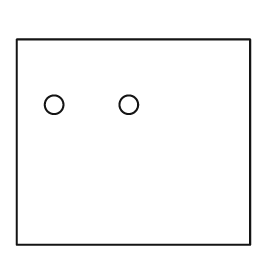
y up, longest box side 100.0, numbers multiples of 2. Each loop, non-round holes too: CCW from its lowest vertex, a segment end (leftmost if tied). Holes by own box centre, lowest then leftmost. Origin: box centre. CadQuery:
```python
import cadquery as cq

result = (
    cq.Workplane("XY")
    .moveTo(-50.0, -44.0)
    .lineTo(50.0, -44.0)
    .lineTo(50.0, 44.0)
    .lineTo(-50.0, 44.0)
    .close()
    .moveTo(-34.0, 16.0)
    .circle(4.0)
    .moveTo(-2.0, 16.0)
    .circle(4.0)
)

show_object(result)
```